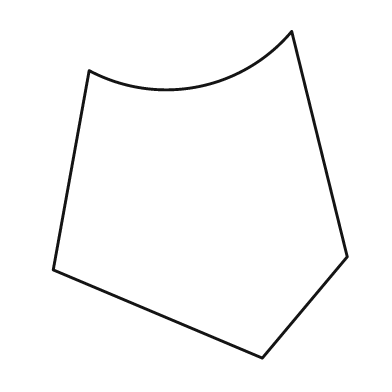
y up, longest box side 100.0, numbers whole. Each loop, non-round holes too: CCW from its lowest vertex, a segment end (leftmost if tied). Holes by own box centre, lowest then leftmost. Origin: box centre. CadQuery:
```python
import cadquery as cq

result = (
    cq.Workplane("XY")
    .moveTo(19.0, -50.0)
    .lineTo(45.0, -19.0)
    .lineTo(28.0, 50.0)
    .threePointArc((-1.0, 33.0), (-34.0, 38.0))
    .lineTo(-45.0, -23.0)
    .close()
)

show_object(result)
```